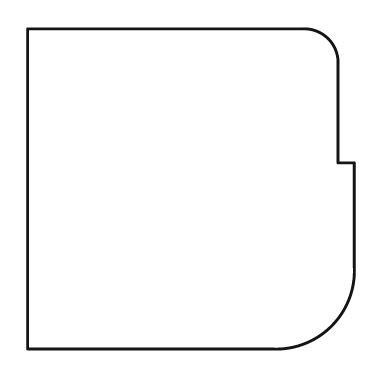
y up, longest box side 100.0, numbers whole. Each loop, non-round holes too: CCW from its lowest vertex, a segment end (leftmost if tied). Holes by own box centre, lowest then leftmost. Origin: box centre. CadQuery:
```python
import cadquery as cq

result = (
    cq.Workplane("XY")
    .moveTo(-50.0, -49.0)
    .lineTo(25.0, -49.0)
    .threePointArc((43.0, -42.0), (50.0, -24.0))
    .lineTo(50.0, 8.0)
    .lineTo(45.0, 8.0)
    .lineTo(45.0, 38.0)
    .threePointArc((42.0, 46.0), (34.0, 49.0))
    .lineTo(-50.0, 49.0)
    .close()
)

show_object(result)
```